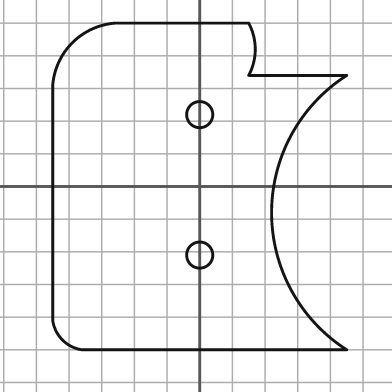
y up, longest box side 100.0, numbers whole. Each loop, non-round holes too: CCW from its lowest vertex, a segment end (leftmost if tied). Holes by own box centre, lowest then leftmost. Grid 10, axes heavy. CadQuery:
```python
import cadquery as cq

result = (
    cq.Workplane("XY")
    .moveTo(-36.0, -50.0)
    .lineTo(45.0, -50.0)
    .threePointArc((22.0, -8.0), (45.0, 34.0))
    .lineTo(15.0, 34.0)
    .threePointArc((17.0, 42.0), (15.0, 50.0))
    .lineTo(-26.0, 50.0)
    .threePointArc((-39.0, 44.0), (-45.0, 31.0))
    .lineTo(-45.0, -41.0)
    .threePointArc((-42.0, -47.0), (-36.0, -50.0))
    .close()
    .moveTo(0.0, -21.0)
    .circle(4.0)
    .moveTo(0.0, 22.0)
    .circle(4.0)
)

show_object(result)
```